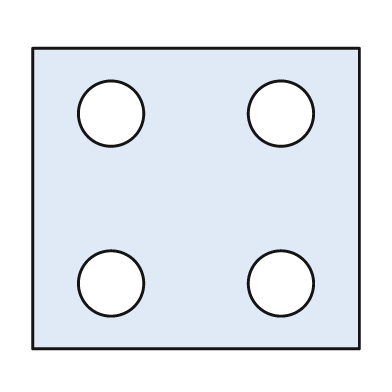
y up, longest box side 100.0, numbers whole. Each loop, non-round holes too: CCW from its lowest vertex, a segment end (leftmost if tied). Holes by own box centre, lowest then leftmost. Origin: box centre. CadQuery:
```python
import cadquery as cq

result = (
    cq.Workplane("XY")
    .moveTo(-50.0, -46.0)
    .lineTo(50.0, -46.0)
    .lineTo(50.0, 46.0)
    .lineTo(-50.0, 46.0)
    .close()
    .moveTo(-26.0, -26.0)
    .circle(10.0)
    .moveTo(26.0, -26.0)
    .circle(10.0)
    .moveTo(-26.0, 26.0)
    .circle(10.0)
    .moveTo(26.0, 26.0)
    .circle(10.0)
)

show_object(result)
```